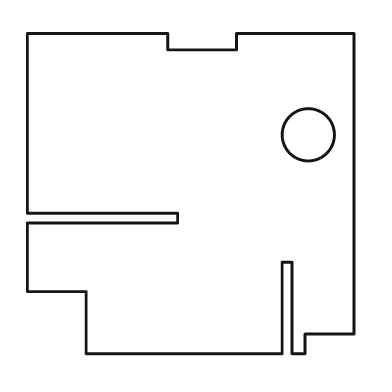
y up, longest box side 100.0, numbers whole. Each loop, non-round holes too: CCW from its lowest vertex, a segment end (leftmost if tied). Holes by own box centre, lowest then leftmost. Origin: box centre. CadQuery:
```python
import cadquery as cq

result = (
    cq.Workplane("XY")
    .moveTo(-32.0, -49.0)
    .lineTo(28.0, -49.0)
    .lineTo(28.0, -21.0)
    .lineTo(31.0, -21.0)
    .lineTo(31.0, -49.0)
    .lineTo(35.0, -49.0)
    .lineTo(35.0, -43.0)
    .lineTo(50.0, -43.0)
    .lineTo(50.0, 49.0)
    .lineTo(14.0, 49.0)
    .lineTo(14.0, 44.0)
    .lineTo(-7.0, 44.0)
    .lineTo(-7.0, 49.0)
    .lineTo(-50.0, 49.0)
    .lineTo(-50.0, -6.0)
    .lineTo(-4.0, -6.0)
    .lineTo(-4.0, -9.0)
    .lineTo(-50.0, -9.0)
    .lineTo(-50.0, -30.0)
    .lineTo(-32.0, -30.0)
    .close()
    .moveTo(36.0, 18.0)
    .circle(8.0)
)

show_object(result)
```